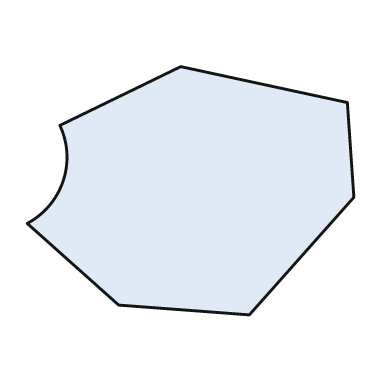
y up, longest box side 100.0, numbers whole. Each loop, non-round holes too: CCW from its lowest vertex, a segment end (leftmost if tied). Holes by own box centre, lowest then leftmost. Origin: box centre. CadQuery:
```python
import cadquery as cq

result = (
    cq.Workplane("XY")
    .moveTo(18.0, -38.0)
    .lineTo(50.0, -2.0)
    .lineTo(48.0, 27.0)
    .lineTo(-3.0, 38.0)
    .lineTo(-40.0, 20.0)
    .threePointArc((-39.0, 3.0), (-50.0, -10.0))
    .lineTo(-22.0, -35.0)
    .close()
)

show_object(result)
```